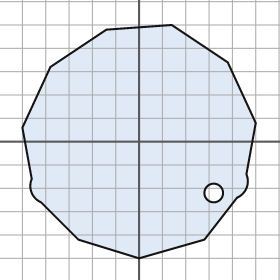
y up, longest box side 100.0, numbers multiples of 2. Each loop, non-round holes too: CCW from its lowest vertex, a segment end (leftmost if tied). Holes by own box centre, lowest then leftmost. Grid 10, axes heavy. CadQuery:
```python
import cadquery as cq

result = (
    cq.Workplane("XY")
    .moveTo(0.0, -50.0)
    .lineTo(28.0, -42.0)
    .lineTo(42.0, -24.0)
    .threePointArc((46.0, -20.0), (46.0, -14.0))
    .lineTo(50.0, 8.0)
    .lineTo(38.0, 34.0)
    .lineTo(14.0, 50.0)
    .lineTo(-14.0, 48.0)
    .lineTo(-38.0, 32.0)
    .lineTo(-50.0, 6.0)
    .lineTo(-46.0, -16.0)
    .threePointArc((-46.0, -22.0), (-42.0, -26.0))
    .lineTo(-26.0, -42.0)
    .close()
    .moveTo(32.0, -22.0)
    .circle(4.0)
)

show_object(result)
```